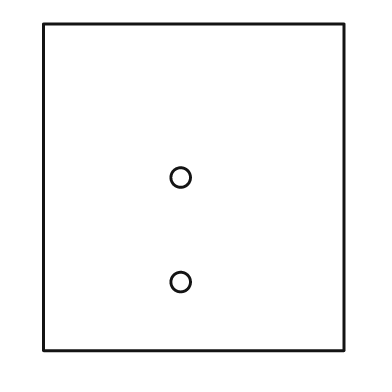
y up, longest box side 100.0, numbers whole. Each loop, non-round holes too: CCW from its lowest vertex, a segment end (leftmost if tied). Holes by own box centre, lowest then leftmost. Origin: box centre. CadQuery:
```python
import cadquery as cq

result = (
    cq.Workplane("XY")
    .moveTo(-46.0, -50.0)
    .lineTo(46.0, -50.0)
    .lineTo(46.0, 50.0)
    .lineTo(-46.0, 50.0)
    .close()
    .moveTo(-4.0, -29.0)
    .circle(3.0)
    .moveTo(-4.0, 3.0)
    .circle(3.0)
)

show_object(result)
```